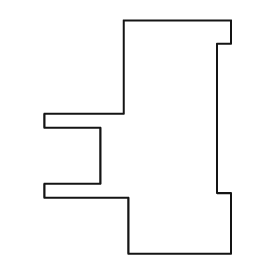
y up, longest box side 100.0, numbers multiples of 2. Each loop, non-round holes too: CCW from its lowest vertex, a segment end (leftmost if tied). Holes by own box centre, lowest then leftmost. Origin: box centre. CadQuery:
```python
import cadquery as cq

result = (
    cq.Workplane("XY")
    .moveTo(-4.0, -50.0)
    .lineTo(40.0, -50.0)
    .lineTo(40.0, -24.0)
    .lineTo(34.0, -24.0)
    .lineTo(34.0, 40.0)
    .lineTo(40.0, 40.0)
    .lineTo(40.0, 50.0)
    .lineTo(-6.0, 50.0)
    .lineTo(-6.0, 10.0)
    .lineTo(-40.0, 10.0)
    .lineTo(-40.0, 4.0)
    .lineTo(-16.0, 4.0)
    .lineTo(-16.0, -20.0)
    .lineTo(-40.0, -20.0)
    .lineTo(-40.0, -26.0)
    .lineTo(-4.0, -26.0)
    .close()
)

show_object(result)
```